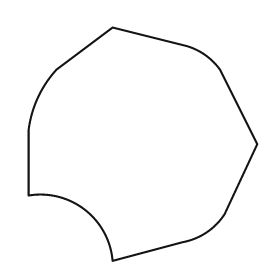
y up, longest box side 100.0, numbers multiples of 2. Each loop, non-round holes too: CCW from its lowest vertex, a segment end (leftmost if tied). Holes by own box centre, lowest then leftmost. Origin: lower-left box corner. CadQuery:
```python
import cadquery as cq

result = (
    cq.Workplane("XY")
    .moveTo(36.0, 0.0)
    .lineTo(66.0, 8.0)
    .threePointArc((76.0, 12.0), (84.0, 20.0))
    .lineTo(98.0, 50.0)
    .lineTo(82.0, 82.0)
    .threePointArc((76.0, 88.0), (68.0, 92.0))
    .lineTo(36.0, 100.0)
    .lineTo(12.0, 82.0)
    .threePointArc((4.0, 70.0), (0.0, 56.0))
    .lineTo(0.0, 28.0)
    .threePointArc((24.0, 22.0), (36.0, 0.0))
    .close()
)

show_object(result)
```